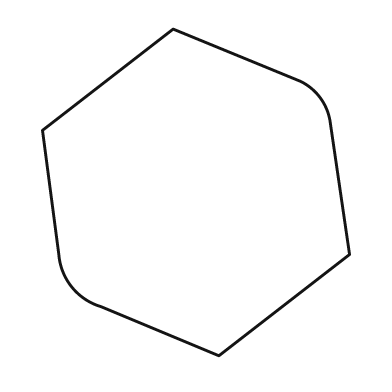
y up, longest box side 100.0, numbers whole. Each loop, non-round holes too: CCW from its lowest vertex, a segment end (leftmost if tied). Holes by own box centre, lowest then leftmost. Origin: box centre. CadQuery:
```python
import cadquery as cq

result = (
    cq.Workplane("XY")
    .moveTo(7.0, -50.0)
    .lineTo(47.0, -19.0)
    .lineTo(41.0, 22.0)
    .threePointArc((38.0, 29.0), (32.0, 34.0))
    .lineTo(-7.0, 50.0)
    .lineTo(-47.0, 19.0)
    .lineTo(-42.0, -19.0)
    .threePointArc((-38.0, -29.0), (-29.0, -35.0))
    .close()
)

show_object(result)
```